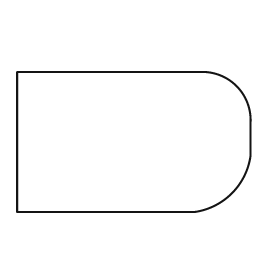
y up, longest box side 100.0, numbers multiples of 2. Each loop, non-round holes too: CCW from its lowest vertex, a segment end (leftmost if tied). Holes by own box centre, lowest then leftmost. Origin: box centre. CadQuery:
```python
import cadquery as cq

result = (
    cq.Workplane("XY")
    .moveTo(-50.0, -30.0)
    .lineTo(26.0, -30.0)
    .threePointArc((42.0, -22.0), (50.0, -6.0))
    .lineTo(50.0, 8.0)
    .threePointArc((44.0, 24.0), (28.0, 30.0))
    .lineTo(-50.0, 30.0)
    .close()
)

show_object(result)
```